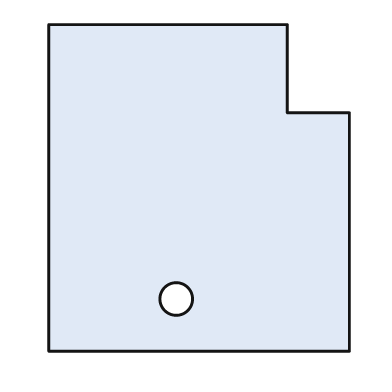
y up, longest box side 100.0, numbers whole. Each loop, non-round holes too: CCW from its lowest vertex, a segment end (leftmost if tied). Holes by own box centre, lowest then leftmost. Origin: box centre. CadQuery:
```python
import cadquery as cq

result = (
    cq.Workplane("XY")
    .moveTo(-46.0, -50.0)
    .lineTo(46.0, -50.0)
    .lineTo(46.0, 23.0)
    .lineTo(27.0, 23.0)
    .lineTo(27.0, 50.0)
    .lineTo(-46.0, 50.0)
    .close()
    .moveTo(-7.0, -34.0)
    .circle(5.0)
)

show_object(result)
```